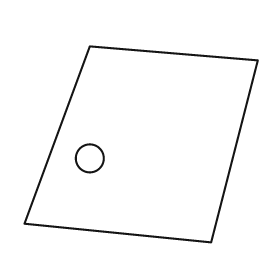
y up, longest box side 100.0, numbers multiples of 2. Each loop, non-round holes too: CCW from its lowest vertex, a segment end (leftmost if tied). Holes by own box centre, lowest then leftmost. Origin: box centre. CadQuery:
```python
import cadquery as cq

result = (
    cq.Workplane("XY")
    .moveTo(30.0, -42.0)
    .lineTo(50.0, 36.0)
    .lineTo(-22.0, 42.0)
    .lineTo(-50.0, -34.0)
    .close()
    .moveTo(-22.0, -6.0)
    .circle(6.0)
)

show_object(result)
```